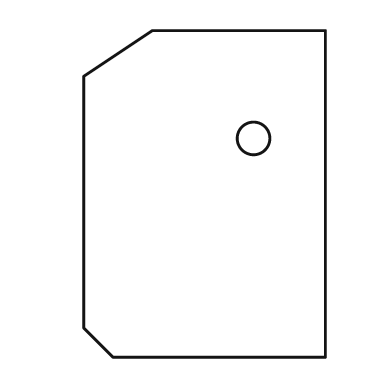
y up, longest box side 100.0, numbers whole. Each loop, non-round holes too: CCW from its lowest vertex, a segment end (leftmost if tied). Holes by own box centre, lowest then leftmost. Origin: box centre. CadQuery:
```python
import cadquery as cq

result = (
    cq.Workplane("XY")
    .moveTo(-28.0, -50.0)
    .lineTo(37.0, -50.0)
    .lineTo(37.0, 50.0)
    .lineTo(-16.0, 50.0)
    .lineTo(-37.0, 36.0)
    .lineTo(-37.0, -41.0)
    .close()
    .moveTo(15.0, 17.0)
    .circle(5.0)
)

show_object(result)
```